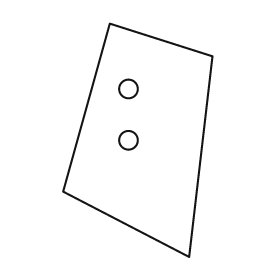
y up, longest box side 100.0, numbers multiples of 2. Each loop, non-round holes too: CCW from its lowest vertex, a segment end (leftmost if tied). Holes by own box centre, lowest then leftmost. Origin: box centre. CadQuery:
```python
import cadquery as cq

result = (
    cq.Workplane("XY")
    .moveTo(22.0, -50.0)
    .lineTo(32.0, 36.0)
    .lineTo(-12.0, 50.0)
    .lineTo(-32.0, -22.0)
    .close()
    .moveTo(-4.0, 0.0)
    .circle(4.0)
    .moveTo(-4.0, 22.0)
    .circle(4.0)
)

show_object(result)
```